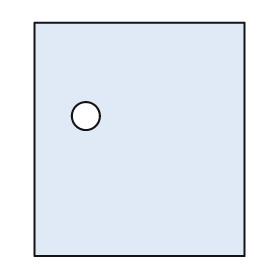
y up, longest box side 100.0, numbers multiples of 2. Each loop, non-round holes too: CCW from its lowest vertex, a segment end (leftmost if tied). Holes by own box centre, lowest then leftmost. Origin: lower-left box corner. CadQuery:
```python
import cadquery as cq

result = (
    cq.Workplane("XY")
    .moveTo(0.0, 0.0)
    .lineTo(90.0, 0.0)
    .lineTo(90.0, 100.0)
    .lineTo(0.0, 100.0)
    .close()
    .moveTo(22.0, 60.0)
    .circle(6.0)
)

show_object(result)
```